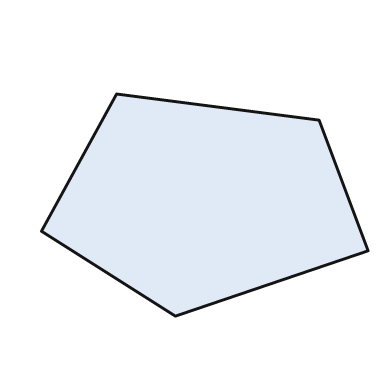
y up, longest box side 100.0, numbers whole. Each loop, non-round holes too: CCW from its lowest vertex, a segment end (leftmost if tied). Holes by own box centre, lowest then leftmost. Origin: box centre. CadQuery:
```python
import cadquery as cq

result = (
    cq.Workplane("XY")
    .moveTo(-9.0, -34.0)
    .lineTo(50.0, -14.0)
    .lineTo(35.0, 26.0)
    .lineTo(-27.0, 34.0)
    .lineTo(-50.0, -8.0)
    .close()
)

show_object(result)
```